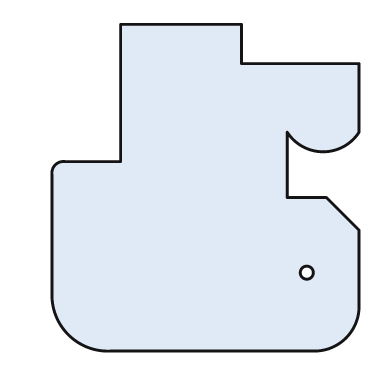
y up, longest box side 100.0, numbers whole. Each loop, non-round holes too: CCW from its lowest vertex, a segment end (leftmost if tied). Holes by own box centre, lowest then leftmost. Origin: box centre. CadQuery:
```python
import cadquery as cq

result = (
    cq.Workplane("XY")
    .moveTo(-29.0, -50.0)
    .lineTo(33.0, -50.0)
    .threePointArc((43.0, -46.0), (47.0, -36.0))
    .lineTo(47.0, -13.0)
    .lineTo(37.0, -3.0)
    .lineTo(25.0, -3.0)
    .lineTo(25.0, 17.0)
    .threePointArc((36.0, 11.0), (47.0, 17.0))
    .lineTo(47.0, 38.0)
    .lineTo(11.0, 38.0)
    .lineTo(11.0, 50.0)
    .lineTo(-26.0, 50.0)
    .lineTo(-26.0, 8.0)
    .lineTo(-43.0, 8.0)
    .threePointArc((-46.0, 7.0), (-47.0, 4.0))
    .lineTo(-47.0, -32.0)
    .threePointArc((-42.0, -45.0), (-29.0, -50.0))
    .close()
    .moveTo(31.0, -26.0)
    .circle(2.0)
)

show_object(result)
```